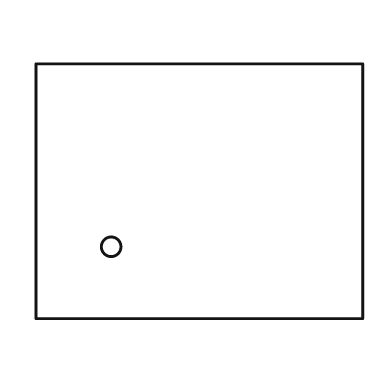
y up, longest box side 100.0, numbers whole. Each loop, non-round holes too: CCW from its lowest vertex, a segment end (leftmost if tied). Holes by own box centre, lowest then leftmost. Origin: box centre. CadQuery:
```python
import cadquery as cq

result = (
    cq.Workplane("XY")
    .moveTo(-50.0, -39.0)
    .lineTo(50.0, -39.0)
    .lineTo(50.0, 39.0)
    .lineTo(-50.0, 39.0)
    .close()
    .moveTo(-27.0, -17.0)
    .circle(3.0)
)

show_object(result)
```